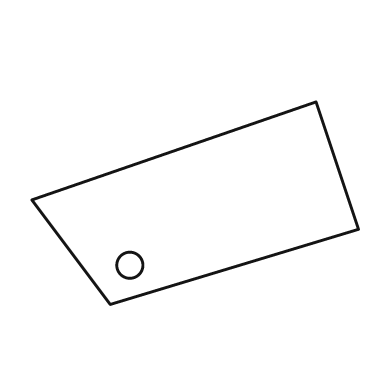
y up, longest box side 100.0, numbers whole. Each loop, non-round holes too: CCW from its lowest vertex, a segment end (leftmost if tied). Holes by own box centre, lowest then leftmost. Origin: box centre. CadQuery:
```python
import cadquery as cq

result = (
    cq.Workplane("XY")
    .moveTo(-26.0, -31.0)
    .lineTo(50.0, -8.0)
    .lineTo(37.0, 31.0)
    .lineTo(-50.0, 1.0)
    .close()
    .moveTo(-20.0, -19.0)
    .circle(4.0)
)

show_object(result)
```